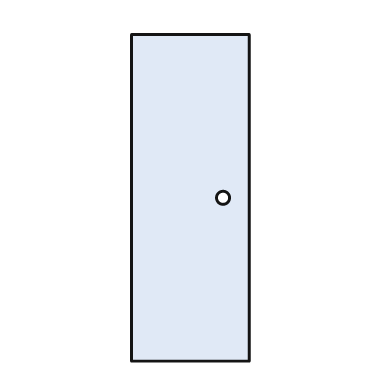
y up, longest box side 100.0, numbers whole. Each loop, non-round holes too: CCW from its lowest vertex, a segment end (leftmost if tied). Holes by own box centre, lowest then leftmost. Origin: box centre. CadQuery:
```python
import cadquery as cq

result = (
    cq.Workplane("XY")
    .moveTo(-18.0, -50.0)
    .lineTo(18.0, -50.0)
    .lineTo(18.0, 50.0)
    .lineTo(-18.0, 50.0)
    .close()
    .moveTo(10.0, 0.0)
    .circle(2.0)
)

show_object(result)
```